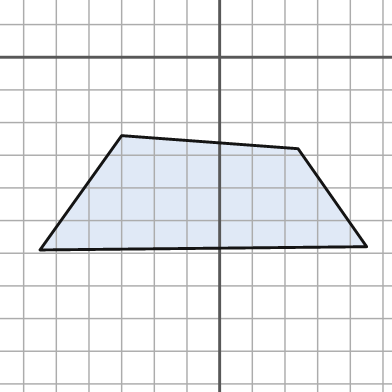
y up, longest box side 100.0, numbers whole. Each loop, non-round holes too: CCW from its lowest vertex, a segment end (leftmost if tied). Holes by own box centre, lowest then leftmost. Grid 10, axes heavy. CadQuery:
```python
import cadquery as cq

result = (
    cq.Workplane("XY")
    .moveTo(-55.0, -59.0)
    .lineTo(45.0, -58.0)
    .lineTo(24.0, -28.0)
    .lineTo(-30.0, -24.0)
    .close()
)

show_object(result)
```